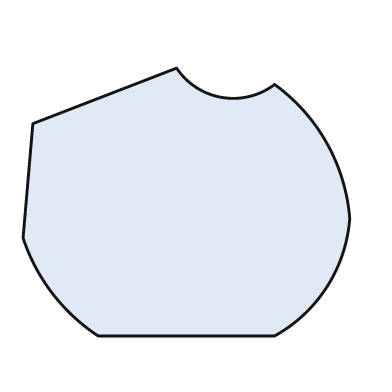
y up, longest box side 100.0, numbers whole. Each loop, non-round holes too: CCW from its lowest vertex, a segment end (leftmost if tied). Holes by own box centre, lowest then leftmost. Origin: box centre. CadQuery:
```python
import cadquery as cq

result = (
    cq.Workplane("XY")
    .moveTo(-27.0, -41.0)
    .lineTo(27.0, -41.0)
    .threePointArc((43.0, -26.0), (50.0, -5.0))
    .threePointArc((43.0, 18.0), (27.0, 36.0))
    .threePointArc((11.0, 32.0), (-3.0, 41.0))
    .lineTo(-47.0, 24.0)
    .lineTo(-50.0, -11.0)
    .threePointArc((-41.0, -28.0), (-27.0, -41.0))
    .close()
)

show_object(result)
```